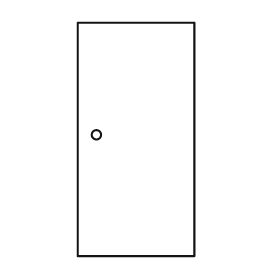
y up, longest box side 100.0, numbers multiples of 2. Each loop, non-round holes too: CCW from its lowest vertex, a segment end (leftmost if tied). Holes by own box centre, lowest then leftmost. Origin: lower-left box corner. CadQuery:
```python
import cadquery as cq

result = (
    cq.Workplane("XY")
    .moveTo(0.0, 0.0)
    .lineTo(50.0, 0.0)
    .lineTo(50.0, 100.0)
    .lineTo(0.0, 100.0)
    .close()
    .moveTo(8.0, 52.0)
    .circle(2.0)
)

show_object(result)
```